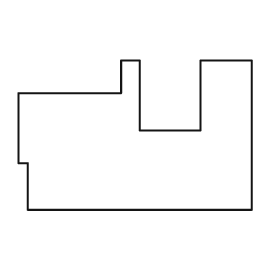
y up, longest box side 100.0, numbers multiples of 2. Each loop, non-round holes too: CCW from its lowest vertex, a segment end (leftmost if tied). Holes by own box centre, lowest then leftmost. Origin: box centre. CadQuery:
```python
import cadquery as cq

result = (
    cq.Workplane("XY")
    .moveTo(-46.0, -32.0)
    .lineTo(50.0, -32.0)
    .lineTo(50.0, 32.0)
    .lineTo(28.0, 32.0)
    .lineTo(28.0, 2.0)
    .lineTo(2.0, 2.0)
    .lineTo(2.0, 32.0)
    .lineTo(-6.0, 32.0)
    .lineTo(-6.0, 18.0)
    .lineTo(-50.0, 18.0)
    .lineTo(-50.0, -12.0)
    .lineTo(-46.0, -12.0)
    .close()
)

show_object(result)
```